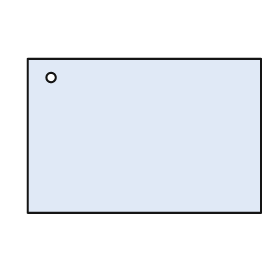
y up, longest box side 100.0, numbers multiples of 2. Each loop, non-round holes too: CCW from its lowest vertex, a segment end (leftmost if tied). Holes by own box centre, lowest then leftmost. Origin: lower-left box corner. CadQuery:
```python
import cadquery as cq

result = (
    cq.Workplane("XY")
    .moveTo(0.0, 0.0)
    .lineTo(100.0, 0.0)
    .lineTo(100.0, 66.0)
    .lineTo(0.0, 66.0)
    .close()
    .moveTo(10.0, 58.0)
    .circle(2.0)
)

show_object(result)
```